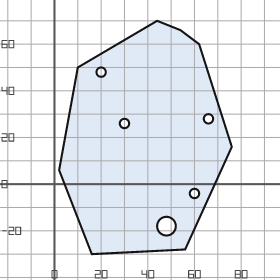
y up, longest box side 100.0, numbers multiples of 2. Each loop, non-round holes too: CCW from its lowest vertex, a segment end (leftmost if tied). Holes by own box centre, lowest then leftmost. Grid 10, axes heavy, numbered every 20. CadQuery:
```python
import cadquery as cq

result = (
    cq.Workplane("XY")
    .moveTo(16.0, -30.0)
    .lineTo(56.0, -28.0)
    .lineTo(76.0, 16.0)
    .lineTo(62.0, 60.0)
    .lineTo(54.0, 66.0)
    .lineTo(44.0, 70.0)
    .lineTo(10.0, 50.0)
    .lineTo(2.0, 6.0)
    .close()
    .moveTo(48.0, -18.0)
    .circle(4.0)
    .moveTo(60.0, -4.0)
    .circle(2.0)
    .moveTo(30.0, 26.0)
    .circle(2.0)
    .moveTo(66.0, 28.0)
    .circle(2.0)
    .moveTo(20.0, 48.0)
    .circle(2.0)
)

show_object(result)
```